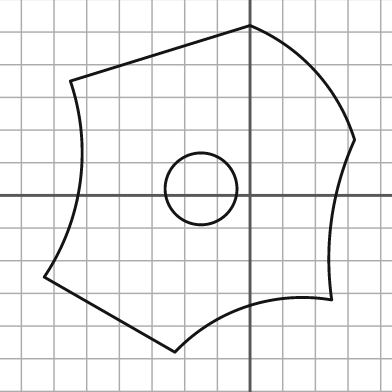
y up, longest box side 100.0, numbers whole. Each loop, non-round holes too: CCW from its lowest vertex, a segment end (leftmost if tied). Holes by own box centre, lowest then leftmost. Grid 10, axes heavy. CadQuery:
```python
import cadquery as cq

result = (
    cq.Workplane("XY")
    .moveTo(-23.0, -48.0)
    .threePointArc((-1.0, -34.0), (25.0, -32.0))
    .threePointArc((25.0, -7.0), (32.0, 17.0))
    .threePointArc((20.0, 38.0), (0.0, 52.0))
    .lineTo(-55.0, 35.0)
    .threePointArc((-52.0, 4.0), (-63.0, -25.0))
    .close()
    .moveTo(-15.0, 2.0)
    .circle(11.0)
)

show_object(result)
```